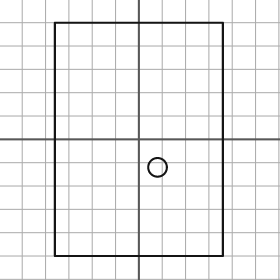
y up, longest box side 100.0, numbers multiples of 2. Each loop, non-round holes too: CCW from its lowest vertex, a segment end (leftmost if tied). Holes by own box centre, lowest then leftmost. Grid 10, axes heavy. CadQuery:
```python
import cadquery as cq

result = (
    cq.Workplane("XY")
    .moveTo(-36.0, -50.0)
    .lineTo(36.0, -50.0)
    .lineTo(36.0, 50.0)
    .lineTo(-36.0, 50.0)
    .close()
    .moveTo(8.0, -12.0)
    .circle(4.0)
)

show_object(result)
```